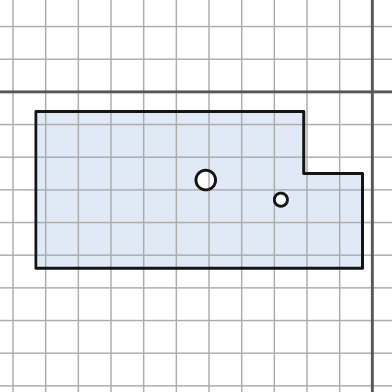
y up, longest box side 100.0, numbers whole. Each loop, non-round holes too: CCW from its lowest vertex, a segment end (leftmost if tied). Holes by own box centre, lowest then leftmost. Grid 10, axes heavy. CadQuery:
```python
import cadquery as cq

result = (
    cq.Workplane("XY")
    .moveTo(-103.0, -54.0)
    .lineTo(-3.0, -54.0)
    .lineTo(-3.0, -25.0)
    .lineTo(-21.0, -25.0)
    .lineTo(-21.0, -6.0)
    .lineTo(-103.0, -6.0)
    .close()
    .moveTo(-28.0, -33.0)
    .circle(2.0)
    .moveTo(-51.0, -27.0)
    .circle(3.0)
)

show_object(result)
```